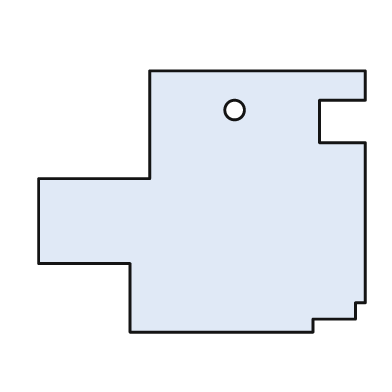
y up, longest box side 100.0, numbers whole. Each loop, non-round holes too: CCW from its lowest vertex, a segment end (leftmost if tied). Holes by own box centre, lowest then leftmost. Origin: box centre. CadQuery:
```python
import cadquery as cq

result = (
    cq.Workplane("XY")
    .moveTo(-22.0, -40.0)
    .lineTo(34.0, -40.0)
    .lineTo(34.0, -36.0)
    .lineTo(47.0, -36.0)
    .lineTo(47.0, -31.0)
    .lineTo(50.0, -31.0)
    .lineTo(50.0, 18.0)
    .lineTo(36.0, 18.0)
    .lineTo(36.0, 31.0)
    .lineTo(50.0, 31.0)
    .lineTo(50.0, 40.0)
    .lineTo(-16.0, 40.0)
    .lineTo(-16.0, 7.0)
    .lineTo(-50.0, 7.0)
    .lineTo(-50.0, -19.0)
    .lineTo(-22.0, -19.0)
    .close()
    .moveTo(10.0, 28.0)
    .circle(3.0)
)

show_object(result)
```